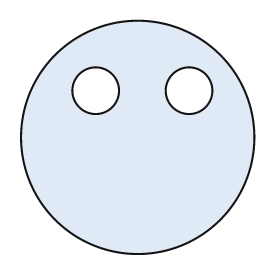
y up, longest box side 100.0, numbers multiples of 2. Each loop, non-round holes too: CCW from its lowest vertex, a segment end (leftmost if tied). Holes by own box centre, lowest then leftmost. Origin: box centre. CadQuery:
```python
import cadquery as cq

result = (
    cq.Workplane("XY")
    .moveTo(0.0, 0.0)
    .circle(50.0)
    .moveTo(-18.0, 20.0)
    .circle(10.0)
    .moveTo(22.0, 20.0)
    .circle(10.0)
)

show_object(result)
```